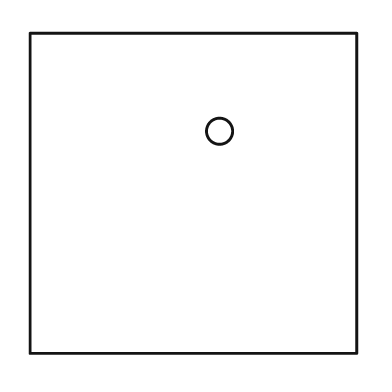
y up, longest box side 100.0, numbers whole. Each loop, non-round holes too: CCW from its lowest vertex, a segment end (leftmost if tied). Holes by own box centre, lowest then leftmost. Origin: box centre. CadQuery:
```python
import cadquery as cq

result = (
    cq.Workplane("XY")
    .moveTo(-50.0, -49.0)
    .lineTo(50.0, -49.0)
    .lineTo(50.0, 49.0)
    .lineTo(-50.0, 49.0)
    .close()
    .moveTo(8.0, 19.0)
    .circle(4.0)
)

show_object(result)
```